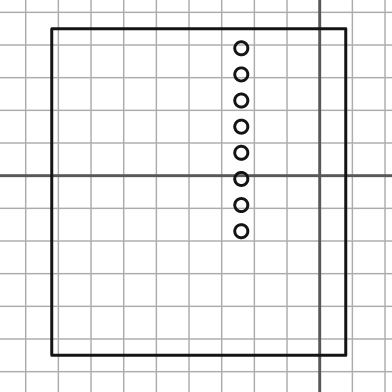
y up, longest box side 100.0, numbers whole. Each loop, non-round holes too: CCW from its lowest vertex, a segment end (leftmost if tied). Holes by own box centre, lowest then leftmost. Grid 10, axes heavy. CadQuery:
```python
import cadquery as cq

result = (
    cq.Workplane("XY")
    .moveTo(-82.0, -55.0)
    .lineTo(8.0, -55.0)
    .lineTo(8.0, 45.0)
    .lineTo(-82.0, 45.0)
    .close()
    .moveTo(-24.0, -17.0)
    .circle(2.0)
    .moveTo(-24.0, -9.0)
    .circle(2.0)
    .moveTo(-24.0, -1.0)
    .circle(2.0)
    .moveTo(-24.0, 7.0)
    .circle(2.0)
    .moveTo(-24.0, 15.0)
    .circle(2.0)
    .moveTo(-24.0, 23.0)
    .circle(2.0)
    .moveTo(-24.0, 31.0)
    .circle(2.0)
    .moveTo(-24.0, 39.0)
    .circle(2.0)
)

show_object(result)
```